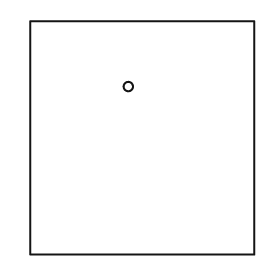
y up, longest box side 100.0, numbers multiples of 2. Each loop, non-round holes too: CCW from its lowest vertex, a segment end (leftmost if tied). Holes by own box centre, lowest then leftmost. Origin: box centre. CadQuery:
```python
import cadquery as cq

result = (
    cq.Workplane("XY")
    .moveTo(-48.0, -50.0)
    .lineTo(48.0, -50.0)
    .lineTo(48.0, 50.0)
    .lineTo(-48.0, 50.0)
    .close()
    .moveTo(-6.0, 22.0)
    .circle(2.0)
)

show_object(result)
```